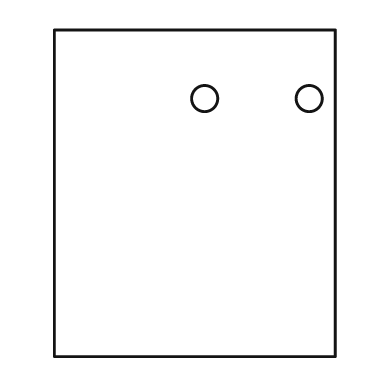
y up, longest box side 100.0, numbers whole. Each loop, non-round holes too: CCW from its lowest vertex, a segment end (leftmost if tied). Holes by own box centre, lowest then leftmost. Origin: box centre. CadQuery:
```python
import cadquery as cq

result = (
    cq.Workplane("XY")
    .moveTo(-43.0, -50.0)
    .lineTo(43.0, -50.0)
    .lineTo(43.0, 50.0)
    .lineTo(-43.0, 50.0)
    .close()
    .moveTo(3.0, 29.0)
    .circle(4.0)
    .moveTo(35.0, 29.0)
    .circle(4.0)
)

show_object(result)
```